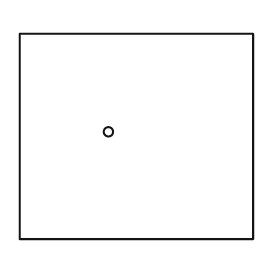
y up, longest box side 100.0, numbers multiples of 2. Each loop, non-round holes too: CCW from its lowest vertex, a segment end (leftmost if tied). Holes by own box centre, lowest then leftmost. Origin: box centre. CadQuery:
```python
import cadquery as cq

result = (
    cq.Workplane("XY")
    .moveTo(-50.0, -44.0)
    .lineTo(50.0, -44.0)
    .lineTo(50.0, 44.0)
    .lineTo(-50.0, 44.0)
    .close()
    .moveTo(-12.0, 2.0)
    .circle(2.0)
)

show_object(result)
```